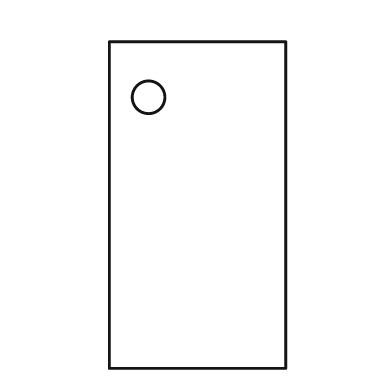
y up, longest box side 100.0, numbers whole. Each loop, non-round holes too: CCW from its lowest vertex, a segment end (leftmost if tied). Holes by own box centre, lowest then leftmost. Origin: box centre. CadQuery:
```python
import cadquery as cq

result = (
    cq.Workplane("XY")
    .moveTo(-27.0, -50.0)
    .lineTo(27.0, -50.0)
    .lineTo(27.0, 50.0)
    .lineTo(-27.0, 50.0)
    .close()
    .moveTo(-15.0, 33.0)
    .circle(5.0)
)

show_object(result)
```